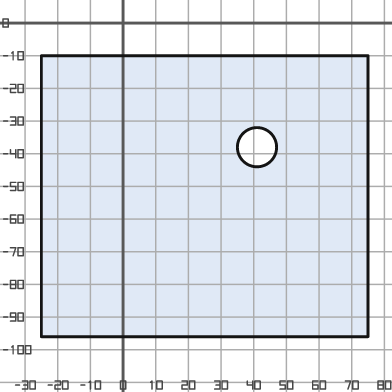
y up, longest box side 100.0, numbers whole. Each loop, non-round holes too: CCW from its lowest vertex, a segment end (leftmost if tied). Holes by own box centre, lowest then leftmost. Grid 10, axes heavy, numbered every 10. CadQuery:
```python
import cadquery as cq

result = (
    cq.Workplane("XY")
    .moveTo(-25.0, -96.0)
    .lineTo(75.0, -96.0)
    .lineTo(75.0, -10.0)
    .lineTo(-25.0, -10.0)
    .close()
    .moveTo(41.0, -38.0)
    .circle(6.0)
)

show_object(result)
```